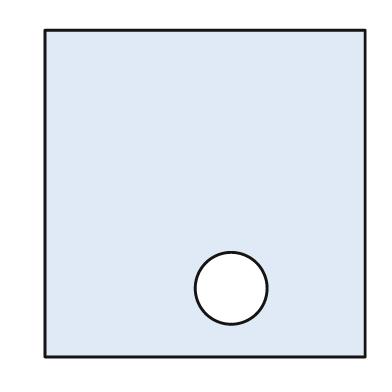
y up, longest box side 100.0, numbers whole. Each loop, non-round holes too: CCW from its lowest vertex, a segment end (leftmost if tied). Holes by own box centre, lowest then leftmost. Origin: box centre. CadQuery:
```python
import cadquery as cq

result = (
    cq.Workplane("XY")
    .moveTo(-49.0, -50.0)
    .lineTo(49.0, -50.0)
    .lineTo(49.0, 50.0)
    .lineTo(-49.0, 50.0)
    .close()
    .moveTo(8.0, -29.0)
    .circle(11.0)
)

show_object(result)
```